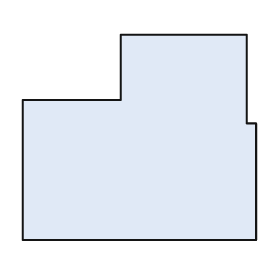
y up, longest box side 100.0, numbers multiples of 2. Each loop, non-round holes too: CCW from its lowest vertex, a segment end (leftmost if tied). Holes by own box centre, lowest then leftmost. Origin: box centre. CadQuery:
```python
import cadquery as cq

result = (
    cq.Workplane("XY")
    .moveTo(-50.0, -44.0)
    .lineTo(50.0, -44.0)
    .lineTo(50.0, 6.0)
    .lineTo(46.0, 6.0)
    .lineTo(46.0, 44.0)
    .lineTo(-8.0, 44.0)
    .lineTo(-8.0, 16.0)
    .lineTo(-50.0, 16.0)
    .close()
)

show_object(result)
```